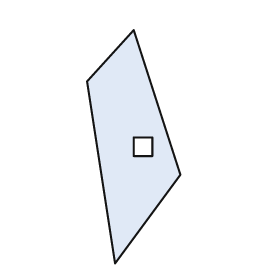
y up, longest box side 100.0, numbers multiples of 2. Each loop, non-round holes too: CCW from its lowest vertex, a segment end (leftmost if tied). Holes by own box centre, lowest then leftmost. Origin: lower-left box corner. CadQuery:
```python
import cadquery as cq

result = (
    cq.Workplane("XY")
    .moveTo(12.0, 0.0)
    .lineTo(40.0, 38.0)
    .lineTo(20.0, 100.0)
    .lineTo(0.0, 78.0)
    .close()
    .moveTo(20.0, 46.0)
    .lineTo(28.0, 46.0)
    .lineTo(28.0, 54.0)
    .lineTo(20.0, 54.0)
    .close()
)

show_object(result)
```